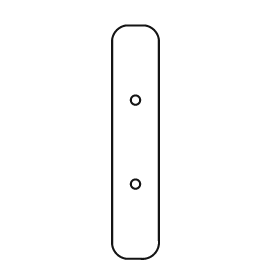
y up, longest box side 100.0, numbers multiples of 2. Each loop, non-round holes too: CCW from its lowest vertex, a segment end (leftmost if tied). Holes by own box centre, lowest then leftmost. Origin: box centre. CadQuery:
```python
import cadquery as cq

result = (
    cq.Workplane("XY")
    .moveTo(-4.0, -50.0)
    .lineTo(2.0, -50.0)
    .threePointArc((8.0, -48.0), (10.0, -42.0))
    .lineTo(10.0, 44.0)
    .threePointArc((8.0, 48.0), (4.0, 50.0))
    .lineTo(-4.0, 50.0)
    .threePointArc((-8.0, 48.0), (-10.0, 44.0))
    .lineTo(-10.0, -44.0)
    .threePointArc((-8.0, -48.0), (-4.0, -50.0))
    .close()
    .moveTo(0.0, -18.0)
    .circle(2.0)
    .moveTo(0.0, 18.0)
    .circle(2.0)
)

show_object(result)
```